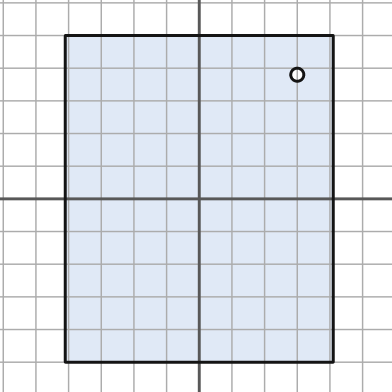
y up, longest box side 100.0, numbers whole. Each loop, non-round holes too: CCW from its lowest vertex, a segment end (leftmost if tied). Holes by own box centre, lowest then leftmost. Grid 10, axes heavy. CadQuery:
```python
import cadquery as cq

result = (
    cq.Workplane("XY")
    .moveTo(-41.0, -50.0)
    .lineTo(41.0, -50.0)
    .lineTo(41.0, 50.0)
    .lineTo(-41.0, 50.0)
    .close()
    .moveTo(30.0, 38.0)
    .circle(2.0)
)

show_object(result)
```